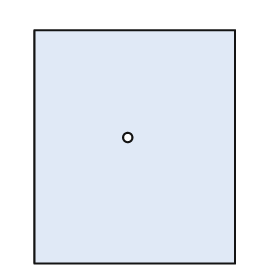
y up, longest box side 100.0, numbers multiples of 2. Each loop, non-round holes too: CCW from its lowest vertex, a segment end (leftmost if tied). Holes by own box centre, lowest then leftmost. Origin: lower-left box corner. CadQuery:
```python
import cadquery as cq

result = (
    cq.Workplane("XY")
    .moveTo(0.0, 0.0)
    .lineTo(86.0, 0.0)
    .lineTo(86.0, 100.0)
    .lineTo(0.0, 100.0)
    .close()
    .moveTo(40.0, 54.0)
    .circle(2.0)
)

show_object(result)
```